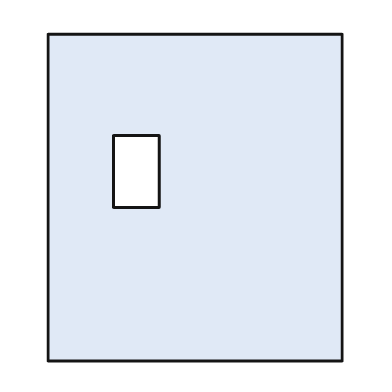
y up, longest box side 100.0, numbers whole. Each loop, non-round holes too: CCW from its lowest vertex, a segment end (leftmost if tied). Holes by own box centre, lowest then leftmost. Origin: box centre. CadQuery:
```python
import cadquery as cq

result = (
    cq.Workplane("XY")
    .moveTo(-45.0, -50.0)
    .lineTo(45.0, -50.0)
    .lineTo(45.0, 50.0)
    .lineTo(-45.0, 50.0)
    .close()
    .moveTo(-25.0, -3.0)
    .lineTo(-11.0, -3.0)
    .lineTo(-11.0, 19.0)
    .lineTo(-25.0, 19.0)
    .close()
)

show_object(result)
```